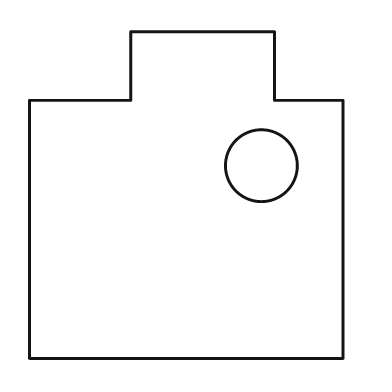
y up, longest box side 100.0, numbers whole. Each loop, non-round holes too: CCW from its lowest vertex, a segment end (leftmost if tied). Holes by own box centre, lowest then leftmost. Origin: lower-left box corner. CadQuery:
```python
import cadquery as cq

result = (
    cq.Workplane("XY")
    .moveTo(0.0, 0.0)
    .lineTo(96.0, 0.0)
    .lineTo(96.0, 79.0)
    .lineTo(75.0, 79.0)
    .lineTo(75.0, 100.0)
    .lineTo(31.0, 100.0)
    .lineTo(31.0, 79.0)
    .lineTo(0.0, 79.0)
    .close()
    .moveTo(71.0, 59.0)
    .circle(11.0)
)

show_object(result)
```